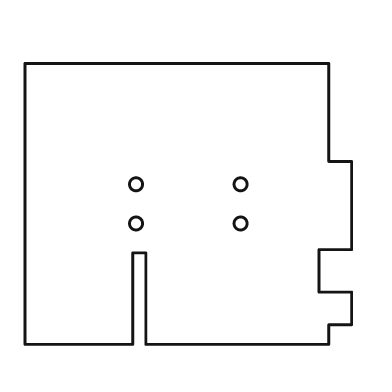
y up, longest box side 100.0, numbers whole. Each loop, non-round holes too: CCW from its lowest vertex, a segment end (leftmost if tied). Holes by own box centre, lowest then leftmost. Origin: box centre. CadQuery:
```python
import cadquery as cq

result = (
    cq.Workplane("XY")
    .moveTo(-50.0, -43.0)
    .lineTo(-17.0, -43.0)
    .lineTo(-17.0, -15.0)
    .lineTo(-13.0, -15.0)
    .lineTo(-13.0, -43.0)
    .lineTo(43.0, -43.0)
    .lineTo(43.0, -37.0)
    .lineTo(50.0, -37.0)
    .lineTo(50.0, -27.0)
    .lineTo(40.0, -27.0)
    .lineTo(40.0, -14.0)
    .lineTo(50.0, -14.0)
    .lineTo(50.0, 13.0)
    .lineTo(43.0, 13.0)
    .lineTo(43.0, 43.0)
    .lineTo(-50.0, 43.0)
    .close()
    .moveTo(-16.0, -6.0)
    .circle(2.0)
    .moveTo(16.0, -6.0)
    .circle(2.0)
    .moveTo(-16.0, 6.0)
    .circle(2.0)
    .moveTo(16.0, 6.0)
    .circle(2.0)
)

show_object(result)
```